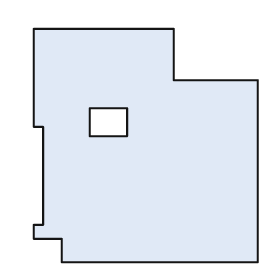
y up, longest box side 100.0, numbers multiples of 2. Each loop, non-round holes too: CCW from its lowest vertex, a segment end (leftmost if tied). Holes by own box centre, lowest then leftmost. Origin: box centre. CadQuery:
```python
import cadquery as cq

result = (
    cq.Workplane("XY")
    .moveTo(-36.0, -50.0)
    .lineTo(48.0, -50.0)
    .lineTo(48.0, 28.0)
    .lineTo(12.0, 28.0)
    .lineTo(12.0, 50.0)
    .lineTo(-48.0, 50.0)
    .lineTo(-48.0, 8.0)
    .lineTo(-44.0, 8.0)
    .lineTo(-44.0, -34.0)
    .lineTo(-48.0, -34.0)
    .lineTo(-48.0, -40.0)
    .lineTo(-36.0, -40.0)
    .close()
    .moveTo(-24.0, 4.0)
    .lineTo(-8.0, 4.0)
    .lineTo(-8.0, 16.0)
    .lineTo(-24.0, 16.0)
    .close()
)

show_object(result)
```